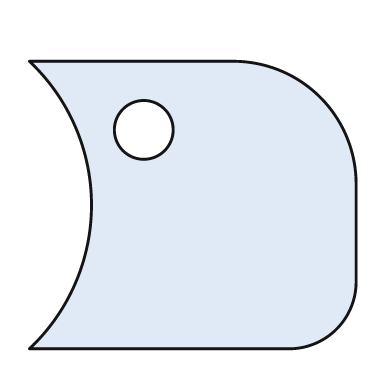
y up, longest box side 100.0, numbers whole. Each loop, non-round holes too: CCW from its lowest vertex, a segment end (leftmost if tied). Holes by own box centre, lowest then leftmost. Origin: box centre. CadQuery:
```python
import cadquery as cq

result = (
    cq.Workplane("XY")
    .moveTo(-50.0, -44.0)
    .lineTo(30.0, -44.0)
    .threePointArc((44.0, -38.0), (50.0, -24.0))
    .lineTo(50.0, 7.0)
    .threePointArc((39.0, 33.0), (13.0, 44.0))
    .lineTo(-50.0, 44.0)
    .threePointArc((-31.0, 0.0), (-50.0, -44.0))
    .close()
    .moveTo(-15.0, 23.0)
    .circle(9.0)
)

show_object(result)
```